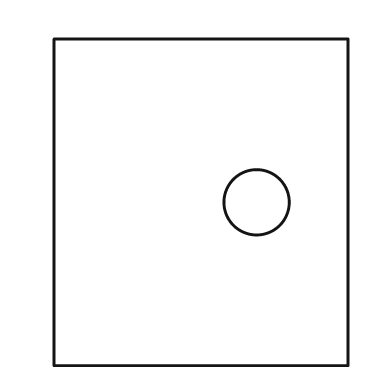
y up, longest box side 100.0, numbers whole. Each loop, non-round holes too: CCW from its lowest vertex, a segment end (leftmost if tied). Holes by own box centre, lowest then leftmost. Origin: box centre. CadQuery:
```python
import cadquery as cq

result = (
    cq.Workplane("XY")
    .moveTo(-45.0, -50.0)
    .lineTo(45.0, -50.0)
    .lineTo(45.0, 50.0)
    .lineTo(-45.0, 50.0)
    .close()
    .moveTo(17.0, 0.0)
    .circle(10.0)
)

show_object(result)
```